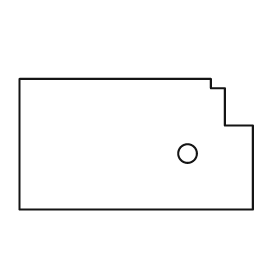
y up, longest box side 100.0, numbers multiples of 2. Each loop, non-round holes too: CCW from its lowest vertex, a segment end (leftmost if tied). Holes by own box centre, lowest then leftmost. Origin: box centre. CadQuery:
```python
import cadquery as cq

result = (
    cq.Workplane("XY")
    .moveTo(-50.0, -28.0)
    .lineTo(50.0, -28.0)
    .lineTo(50.0, 8.0)
    .lineTo(38.0, 8.0)
    .lineTo(38.0, 24.0)
    .lineTo(32.0, 24.0)
    .lineTo(32.0, 28.0)
    .lineTo(-50.0, 28.0)
    .close()
    .moveTo(22.0, -4.0)
    .circle(4.0)
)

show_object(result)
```